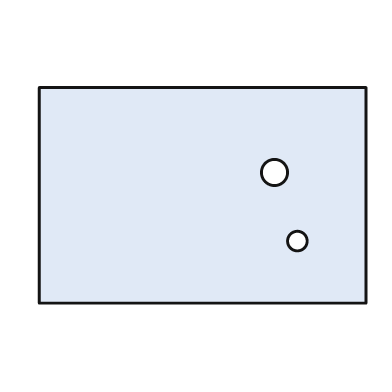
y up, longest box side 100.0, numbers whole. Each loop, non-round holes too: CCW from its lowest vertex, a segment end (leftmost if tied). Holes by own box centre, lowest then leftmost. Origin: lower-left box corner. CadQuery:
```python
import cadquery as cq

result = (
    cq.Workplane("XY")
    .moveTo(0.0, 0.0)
    .lineTo(100.0, 0.0)
    .lineTo(100.0, 66.0)
    .lineTo(0.0, 66.0)
    .close()
    .moveTo(79.0, 19.0)
    .circle(3.0)
    .moveTo(72.0, 40.0)
    .circle(4.0)
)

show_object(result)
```